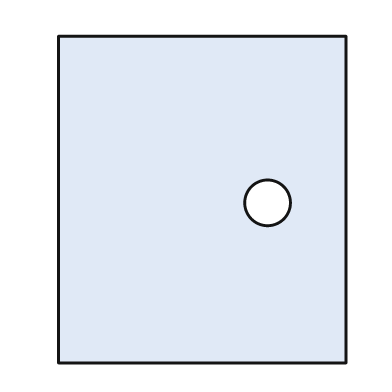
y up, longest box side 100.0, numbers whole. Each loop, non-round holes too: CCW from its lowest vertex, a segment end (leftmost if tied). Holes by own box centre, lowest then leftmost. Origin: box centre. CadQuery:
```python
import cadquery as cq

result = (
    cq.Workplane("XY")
    .moveTo(-44.0, -50.0)
    .lineTo(44.0, -50.0)
    .lineTo(44.0, 50.0)
    .lineTo(-44.0, 50.0)
    .close()
    .moveTo(20.0, -1.0)
    .circle(7.0)
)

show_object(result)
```